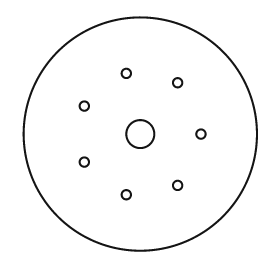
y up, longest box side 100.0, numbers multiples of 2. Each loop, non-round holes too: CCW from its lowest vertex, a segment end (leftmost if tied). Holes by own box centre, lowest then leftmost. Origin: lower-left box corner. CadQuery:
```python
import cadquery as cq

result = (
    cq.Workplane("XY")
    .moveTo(50.0, 50.0)
    .circle(50.0)
    .moveTo(44.0, 24.0)
    .circle(2.0)
    .moveTo(66.0, 28.0)
    .circle(2.0)
    .moveTo(26.0, 38.0)
    .circle(2.0)
    .moveTo(50.0, 50.0)
    .circle(6.0)
    .moveTo(76.0, 50.0)
    .circle(2.0)
    .moveTo(26.0, 62.0)
    .circle(2.0)
    .moveTo(66.0, 72.0)
    .circle(2.0)
    .moveTo(44.0, 76.0)
    .circle(2.0)
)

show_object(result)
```